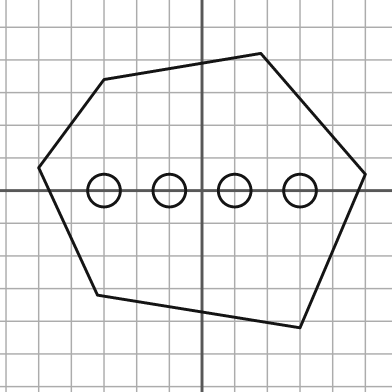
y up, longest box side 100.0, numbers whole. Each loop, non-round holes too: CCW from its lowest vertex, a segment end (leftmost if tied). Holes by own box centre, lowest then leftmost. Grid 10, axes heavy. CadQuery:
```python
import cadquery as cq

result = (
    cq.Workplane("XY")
    .moveTo(30.0, -42.0)
    .lineTo(50.0, 5.0)
    .lineTo(18.0, 42.0)
    .lineTo(-30.0, 34.0)
    .lineTo(-50.0, 7.0)
    .lineTo(-32.0, -32.0)
    .close()
    .moveTo(-30.0, 0.0)
    .circle(5.0)
    .moveTo(-10.0, 0.0)
    .circle(5.0)
    .moveTo(10.0, 0.0)
    .circle(5.0)
    .moveTo(30.0, 0.0)
    .circle(5.0)
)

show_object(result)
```